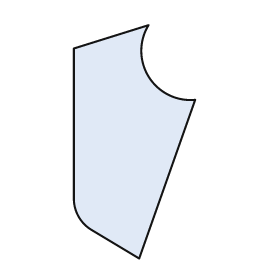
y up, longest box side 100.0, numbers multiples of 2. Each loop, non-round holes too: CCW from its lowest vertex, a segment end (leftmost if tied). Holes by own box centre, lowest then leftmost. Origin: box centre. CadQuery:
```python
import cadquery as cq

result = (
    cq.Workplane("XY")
    .moveTo(2.0, -50.0)
    .lineTo(26.0, 18.0)
    .threePointArc((6.0, 28.0), (6.0, 50.0))
    .lineTo(-26.0, 40.0)
    .lineTo(-26.0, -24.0)
    .threePointArc((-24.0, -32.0), (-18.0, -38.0))
    .close()
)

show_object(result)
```